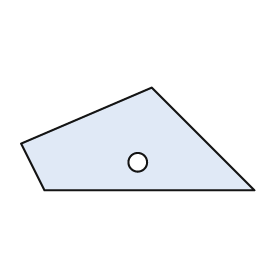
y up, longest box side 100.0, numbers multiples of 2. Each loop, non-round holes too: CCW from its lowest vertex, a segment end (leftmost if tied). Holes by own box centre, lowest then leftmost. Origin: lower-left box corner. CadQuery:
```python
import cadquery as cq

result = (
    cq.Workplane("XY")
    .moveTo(10.0, 0.0)
    .lineTo(100.0, 0.0)
    .lineTo(56.0, 44.0)
    .lineTo(0.0, 20.0)
    .close()
    .moveTo(50.0, 12.0)
    .circle(4.0)
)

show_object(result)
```